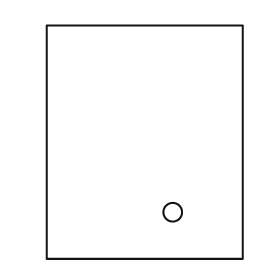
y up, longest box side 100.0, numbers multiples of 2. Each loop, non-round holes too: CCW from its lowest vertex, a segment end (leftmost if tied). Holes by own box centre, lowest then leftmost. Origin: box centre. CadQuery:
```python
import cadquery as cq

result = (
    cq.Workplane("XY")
    .moveTo(-42.0, -50.0)
    .lineTo(42.0, -50.0)
    .lineTo(42.0, 50.0)
    .lineTo(-42.0, 50.0)
    .close()
    .moveTo(12.0, -30.0)
    .circle(4.0)
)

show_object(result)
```